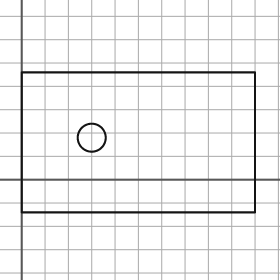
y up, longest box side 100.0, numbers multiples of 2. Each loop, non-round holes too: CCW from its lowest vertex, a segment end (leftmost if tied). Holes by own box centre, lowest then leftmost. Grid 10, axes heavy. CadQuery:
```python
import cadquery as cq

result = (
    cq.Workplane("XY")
    .moveTo(0.0, -14.0)
    .lineTo(100.0, -14.0)
    .lineTo(100.0, 46.0)
    .lineTo(0.0, 46.0)
    .close()
    .moveTo(30.0, 18.0)
    .circle(6.0)
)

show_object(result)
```